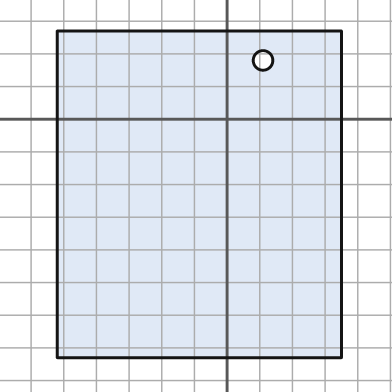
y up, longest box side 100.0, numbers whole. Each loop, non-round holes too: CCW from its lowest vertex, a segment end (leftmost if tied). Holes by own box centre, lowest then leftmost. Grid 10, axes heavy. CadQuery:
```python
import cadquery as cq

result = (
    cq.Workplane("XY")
    .moveTo(-52.0, -73.0)
    .lineTo(35.0, -73.0)
    .lineTo(35.0, 27.0)
    .lineTo(-52.0, 27.0)
    .close()
    .moveTo(11.0, 18.0)
    .circle(3.0)
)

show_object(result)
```